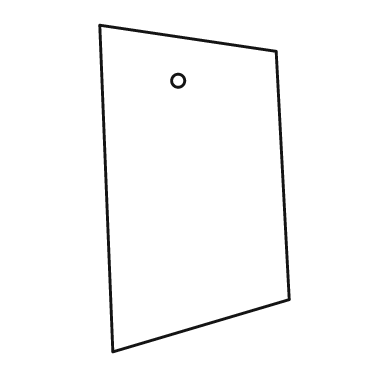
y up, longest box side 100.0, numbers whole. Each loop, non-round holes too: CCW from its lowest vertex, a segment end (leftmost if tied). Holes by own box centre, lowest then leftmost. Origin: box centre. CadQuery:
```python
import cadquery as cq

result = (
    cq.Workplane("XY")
    .moveTo(-25.0, -50.0)
    .lineTo(29.0, -34.0)
    .lineTo(25.0, 42.0)
    .lineTo(-29.0, 50.0)
    .close()
    .moveTo(-5.0, 33.0)
    .circle(2.0)
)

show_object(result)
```